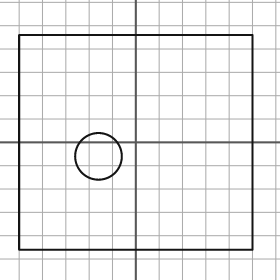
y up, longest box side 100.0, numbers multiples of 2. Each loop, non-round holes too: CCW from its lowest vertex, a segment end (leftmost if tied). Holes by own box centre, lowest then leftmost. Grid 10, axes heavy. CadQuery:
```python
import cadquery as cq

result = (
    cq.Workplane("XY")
    .moveTo(-50.0, -46.0)
    .lineTo(50.0, -46.0)
    .lineTo(50.0, 46.0)
    .lineTo(-50.0, 46.0)
    .close()
    .moveTo(-16.0, -6.0)
    .circle(10.0)
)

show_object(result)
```